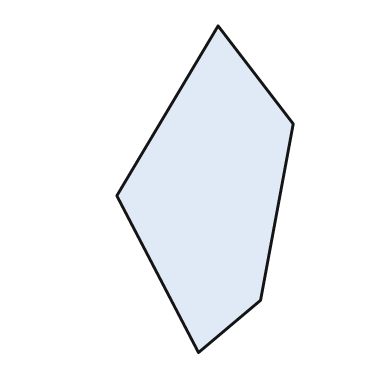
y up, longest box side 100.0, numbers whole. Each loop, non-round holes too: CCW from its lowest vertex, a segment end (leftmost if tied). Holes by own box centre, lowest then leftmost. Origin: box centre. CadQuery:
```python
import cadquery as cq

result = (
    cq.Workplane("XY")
    .moveTo(-2.0, -50.0)
    .lineTo(17.0, -34.0)
    .lineTo(27.0, 20.0)
    .lineTo(4.0, 50.0)
    .lineTo(-27.0, -2.0)
    .close()
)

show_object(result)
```